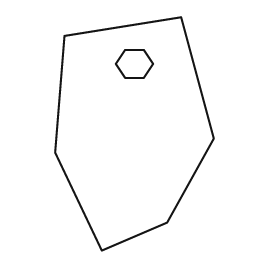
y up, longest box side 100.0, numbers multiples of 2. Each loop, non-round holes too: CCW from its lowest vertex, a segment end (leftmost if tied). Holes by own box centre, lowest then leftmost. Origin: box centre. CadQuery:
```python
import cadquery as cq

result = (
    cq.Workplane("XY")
    .moveTo(-14.0, -50.0)
    .lineTo(14.0, -38.0)
    .lineTo(34.0, -2.0)
    .lineTo(20.0, 50.0)
    .lineTo(-30.0, 42.0)
    .lineTo(-34.0, -8.0)
    .close()
    .moveTo(-4.0, 24.0)
    .lineTo(4.0, 24.0)
    .lineTo(8.0, 30.0)
    .lineTo(4.0, 36.0)
    .lineTo(-4.0, 36.0)
    .lineTo(-8.0, 30.0)
    .close()
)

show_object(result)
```